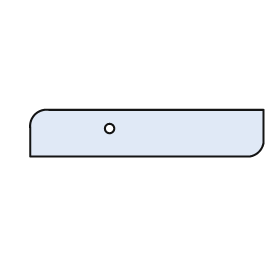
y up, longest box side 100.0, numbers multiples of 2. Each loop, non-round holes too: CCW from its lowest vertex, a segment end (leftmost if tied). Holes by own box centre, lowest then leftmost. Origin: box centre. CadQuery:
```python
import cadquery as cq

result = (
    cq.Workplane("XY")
    .moveTo(-50.0, -10.0)
    .lineTo(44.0, -10.0)
    .threePointArc((48.0, -8.0), (50.0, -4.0))
    .lineTo(50.0, 10.0)
    .lineTo(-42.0, 10.0)
    .threePointArc((-48.0, 8.0), (-50.0, 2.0))
    .close()
    .moveTo(-16.0, 2.0)
    .circle(2.0)
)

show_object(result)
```